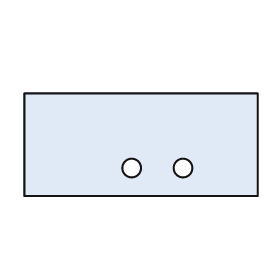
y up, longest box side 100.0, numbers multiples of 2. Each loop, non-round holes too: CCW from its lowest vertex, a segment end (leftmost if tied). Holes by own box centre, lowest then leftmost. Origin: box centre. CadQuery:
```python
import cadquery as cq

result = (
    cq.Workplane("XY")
    .moveTo(-50.0, -22.0)
    .lineTo(50.0, -22.0)
    .lineTo(50.0, 22.0)
    .lineTo(-50.0, 22.0)
    .close()
    .moveTo(-4.0, -10.0)
    .circle(4.0)
    .moveTo(18.0, -10.0)
    .circle(4.0)
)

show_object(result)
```